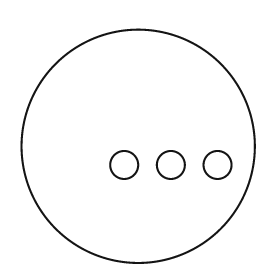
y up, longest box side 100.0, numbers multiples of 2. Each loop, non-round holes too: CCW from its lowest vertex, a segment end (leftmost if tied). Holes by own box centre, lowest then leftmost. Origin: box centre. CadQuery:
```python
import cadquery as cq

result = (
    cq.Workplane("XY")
    .moveTo(0.0, 0.0)
    .circle(50.0)
    .moveTo(-6.0, -8.0)
    .circle(6.0)
    .moveTo(14.0, -8.0)
    .circle(6.0)
    .moveTo(34.0, -8.0)
    .circle(6.0)
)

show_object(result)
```